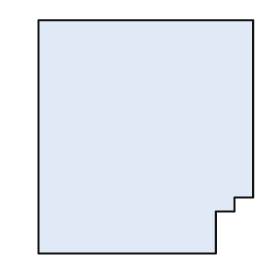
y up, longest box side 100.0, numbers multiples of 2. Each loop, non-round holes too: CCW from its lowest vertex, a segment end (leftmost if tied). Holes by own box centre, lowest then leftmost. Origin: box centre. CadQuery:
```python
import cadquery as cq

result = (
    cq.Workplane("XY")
    .moveTo(-46.0, -50.0)
    .lineTo(30.0, -50.0)
    .lineTo(30.0, -32.0)
    .lineTo(38.0, -32.0)
    .lineTo(38.0, -26.0)
    .lineTo(46.0, -26.0)
    .lineTo(46.0, 50.0)
    .lineTo(-46.0, 50.0)
    .close()
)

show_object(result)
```